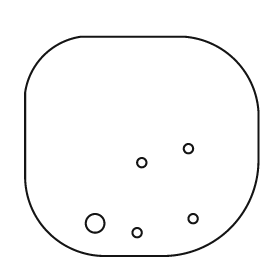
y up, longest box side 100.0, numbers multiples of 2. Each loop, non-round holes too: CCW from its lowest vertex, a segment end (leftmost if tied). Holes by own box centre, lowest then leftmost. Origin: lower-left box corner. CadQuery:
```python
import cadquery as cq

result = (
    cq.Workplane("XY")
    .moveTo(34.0, 0.0)
    .lineTo(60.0, 0.0)
    .threePointArc((88.0, 12.0), (100.0, 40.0))
    .lineTo(100.0, 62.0)
    .threePointArc((90.0, 84.0), (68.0, 94.0))
    .lineTo(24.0, 94.0)
    .threePointArc((8.0, 86.0), (0.0, 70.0))
    .lineTo(0.0, 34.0)
    .threePointArc((10.0, 10.0), (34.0, 0.0))
    .close()
    .moveTo(48.0, 10.0)
    .circle(2.0)
    .moveTo(30.0, 14.0)
    .circle(4.0)
    .moveTo(72.0, 16.0)
    .circle(2.0)
    .moveTo(50.0, 40.0)
    .circle(2.0)
    .moveTo(70.0, 46.0)
    .circle(2.0)
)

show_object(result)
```